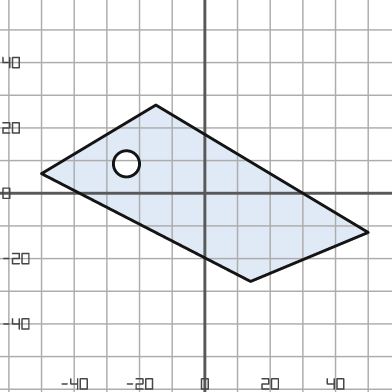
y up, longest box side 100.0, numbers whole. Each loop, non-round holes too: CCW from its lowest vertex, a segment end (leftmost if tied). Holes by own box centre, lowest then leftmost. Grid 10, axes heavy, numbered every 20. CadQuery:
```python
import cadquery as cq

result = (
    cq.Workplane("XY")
    .moveTo(14.0, -27.0)
    .lineTo(50.0, -12.0)
    .lineTo(-15.0, 27.0)
    .lineTo(-50.0, 6.0)
    .close()
    .moveTo(-24.0, 9.0)
    .circle(4.0)
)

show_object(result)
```